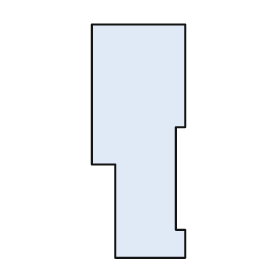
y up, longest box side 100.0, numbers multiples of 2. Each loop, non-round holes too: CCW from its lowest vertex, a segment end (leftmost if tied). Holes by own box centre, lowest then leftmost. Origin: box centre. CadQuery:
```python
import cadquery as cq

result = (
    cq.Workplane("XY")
    .moveTo(-10.0, -50.0)
    .lineTo(20.0, -50.0)
    .lineTo(20.0, -38.0)
    .lineTo(16.0, -38.0)
    .lineTo(16.0, 6.0)
    .lineTo(20.0, 6.0)
    .lineTo(20.0, 50.0)
    .lineTo(-20.0, 50.0)
    .lineTo(-20.0, -10.0)
    .lineTo(-10.0, -10.0)
    .close()
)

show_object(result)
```